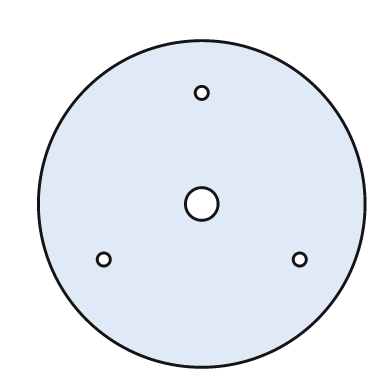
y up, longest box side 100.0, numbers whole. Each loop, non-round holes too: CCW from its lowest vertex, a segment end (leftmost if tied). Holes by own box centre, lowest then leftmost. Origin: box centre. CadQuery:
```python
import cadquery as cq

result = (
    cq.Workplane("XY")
    .moveTo(0.0, 0.0)
    .circle(50.0)
    .moveTo(-30.0, -17.0)
    .circle(2.0)
    .moveTo(30.0, -17.0)
    .circle(2.0)
    .moveTo(0.0, 0.0)
    .circle(5.0)
    .moveTo(0.0, 34.0)
    .circle(2.0)
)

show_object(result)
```